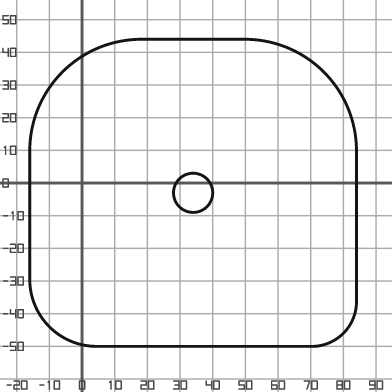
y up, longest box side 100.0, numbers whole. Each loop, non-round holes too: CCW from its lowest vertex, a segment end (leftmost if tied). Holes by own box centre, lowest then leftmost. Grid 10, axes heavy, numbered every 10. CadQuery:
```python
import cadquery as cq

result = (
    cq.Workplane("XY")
    .moveTo(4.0, -50.0)
    .lineTo(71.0, -50.0)
    .threePointArc((80.0, -46.0), (84.0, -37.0))
    .lineTo(84.0, 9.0)
    .threePointArc((74.0, 34.0), (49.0, 44.0))
    .lineTo(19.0, 44.0)
    .threePointArc((-6.0, 34.0), (-16.0, 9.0))
    .lineTo(-16.0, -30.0)
    .threePointArc((-10.0, -44.0), (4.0, -50.0))
    .close()
    .moveTo(34.0, -3.0)
    .circle(6.0)
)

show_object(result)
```